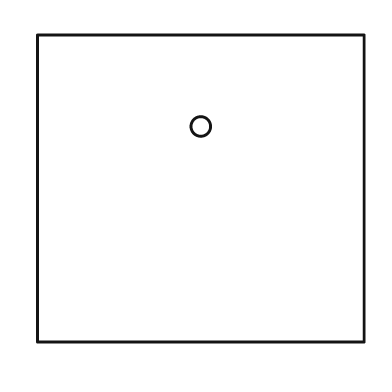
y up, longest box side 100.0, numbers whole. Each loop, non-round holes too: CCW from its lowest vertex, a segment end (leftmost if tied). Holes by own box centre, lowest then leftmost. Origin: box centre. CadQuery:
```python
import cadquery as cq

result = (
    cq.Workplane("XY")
    .moveTo(-50.0, -47.0)
    .lineTo(50.0, -47.0)
    .lineTo(50.0, 47.0)
    .lineTo(-50.0, 47.0)
    .close()
    .moveTo(0.0, 19.0)
    .circle(3.0)
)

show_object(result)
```